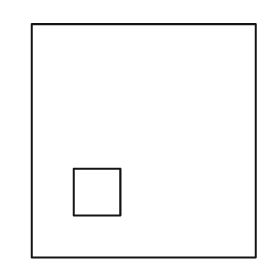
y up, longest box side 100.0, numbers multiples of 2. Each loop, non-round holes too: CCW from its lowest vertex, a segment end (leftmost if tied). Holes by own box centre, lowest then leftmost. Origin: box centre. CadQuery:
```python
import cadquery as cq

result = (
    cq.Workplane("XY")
    .moveTo(-48.0, -50.0)
    .lineTo(48.0, -50.0)
    .lineTo(48.0, 50.0)
    .lineTo(-48.0, 50.0)
    .close()
    .moveTo(-30.0, -32.0)
    .lineTo(-10.0, -32.0)
    .lineTo(-10.0, -12.0)
    .lineTo(-30.0, -12.0)
    .close()
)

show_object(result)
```